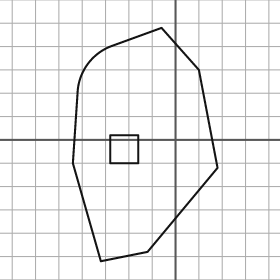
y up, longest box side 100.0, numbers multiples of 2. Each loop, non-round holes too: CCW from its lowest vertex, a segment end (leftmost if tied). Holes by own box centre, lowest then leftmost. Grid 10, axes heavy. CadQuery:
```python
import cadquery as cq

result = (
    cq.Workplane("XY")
    .moveTo(-32.0, -52.0)
    .lineTo(-12.0, -48.0)
    .lineTo(18.0, -12.0)
    .lineTo(10.0, 30.0)
    .lineTo(-6.0, 48.0)
    .lineTo(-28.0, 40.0)
    .threePointArc((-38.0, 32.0), (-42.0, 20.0))
    .lineTo(-44.0, -10.0)
    .close()
    .moveTo(-28.0, -10.0)
    .lineTo(-16.0, -10.0)
    .lineTo(-16.0, 2.0)
    .lineTo(-28.0, 2.0)
    .close()
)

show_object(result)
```